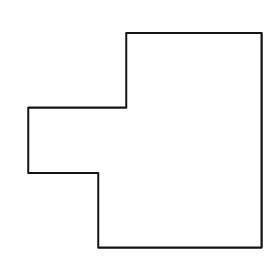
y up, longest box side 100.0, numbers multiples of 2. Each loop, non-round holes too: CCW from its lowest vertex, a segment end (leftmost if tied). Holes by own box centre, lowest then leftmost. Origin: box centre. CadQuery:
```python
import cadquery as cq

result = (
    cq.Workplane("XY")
    .moveTo(-20.0, -46.0)
    .lineTo(50.0, -46.0)
    .lineTo(50.0, 46.0)
    .lineTo(-8.0, 46.0)
    .lineTo(-8.0, 14.0)
    .lineTo(-50.0, 14.0)
    .lineTo(-50.0, -14.0)
    .lineTo(-20.0, -14.0)
    .close()
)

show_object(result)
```